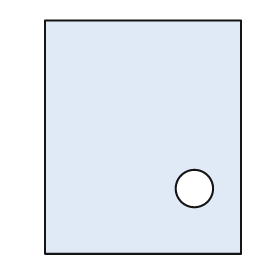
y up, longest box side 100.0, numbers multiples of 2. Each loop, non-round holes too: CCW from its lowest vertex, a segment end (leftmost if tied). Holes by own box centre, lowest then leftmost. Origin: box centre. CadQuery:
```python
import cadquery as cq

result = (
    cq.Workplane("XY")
    .moveTo(-42.0, -50.0)
    .lineTo(42.0, -50.0)
    .lineTo(42.0, 50.0)
    .lineTo(-42.0, 50.0)
    .close()
    .moveTo(22.0, -22.0)
    .circle(8.0)
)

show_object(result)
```